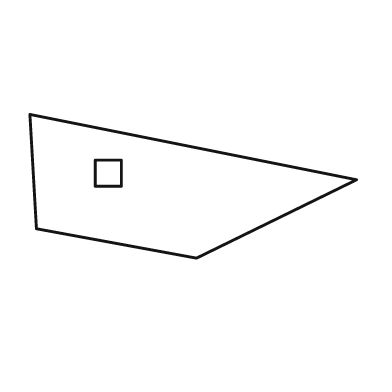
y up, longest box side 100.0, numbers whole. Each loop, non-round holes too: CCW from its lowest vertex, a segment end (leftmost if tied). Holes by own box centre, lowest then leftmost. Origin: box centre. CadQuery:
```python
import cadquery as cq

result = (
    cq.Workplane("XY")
    .moveTo(1.0, -22.0)
    .lineTo(50.0, 2.0)
    .lineTo(-50.0, 22.0)
    .lineTo(-48.0, -13.0)
    .close()
    .moveTo(-30.0, 0.0)
    .lineTo(-22.0, 0.0)
    .lineTo(-22.0, 8.0)
    .lineTo(-30.0, 8.0)
    .close()
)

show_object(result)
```